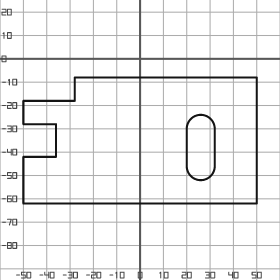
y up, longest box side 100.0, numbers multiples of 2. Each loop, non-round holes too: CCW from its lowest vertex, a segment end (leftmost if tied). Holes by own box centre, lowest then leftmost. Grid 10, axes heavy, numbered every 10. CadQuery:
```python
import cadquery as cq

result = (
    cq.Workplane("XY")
    .moveTo(-50.0, -62.0)
    .lineTo(50.0, -62.0)
    .lineTo(50.0, -8.0)
    .lineTo(-28.0, -8.0)
    .lineTo(-28.0, -18.0)
    .lineTo(-50.0, -18.0)
    .lineTo(-50.0, -28.0)
    .lineTo(-36.0, -28.0)
    .lineTo(-36.0, -42.0)
    .lineTo(-50.0, -42.0)
    .close()
    .moveTo(20.0, -46.0)
    .threePointArc((26.0, -52.0), (32.0, -46.0))
    .lineTo(32.0, -30.0)
    .threePointArc((26.0, -24.0), (20.0, -30.0))
    .close()
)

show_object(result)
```